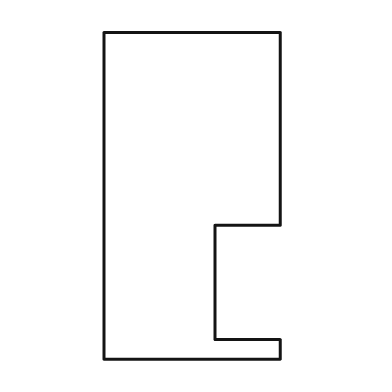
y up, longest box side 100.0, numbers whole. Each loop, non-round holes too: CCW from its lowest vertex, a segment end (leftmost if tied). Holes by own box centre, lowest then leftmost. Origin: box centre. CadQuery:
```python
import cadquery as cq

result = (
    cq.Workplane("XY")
    .moveTo(-27.0, -50.0)
    .lineTo(27.0, -50.0)
    .lineTo(27.0, -44.0)
    .lineTo(7.0, -44.0)
    .lineTo(7.0, -9.0)
    .lineTo(27.0, -9.0)
    .lineTo(27.0, 50.0)
    .lineTo(-27.0, 50.0)
    .close()
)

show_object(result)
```